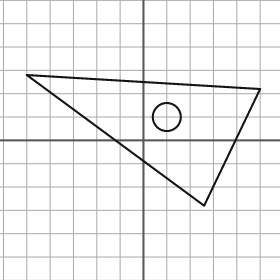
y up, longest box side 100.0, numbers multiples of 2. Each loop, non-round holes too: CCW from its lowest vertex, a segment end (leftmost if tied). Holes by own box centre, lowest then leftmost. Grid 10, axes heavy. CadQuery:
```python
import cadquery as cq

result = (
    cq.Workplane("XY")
    .moveTo(26.0, -28.0)
    .lineTo(50.0, 22.0)
    .lineTo(-50.0, 28.0)
    .close()
    .moveTo(10.0, 10.0)
    .circle(6.0)
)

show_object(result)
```